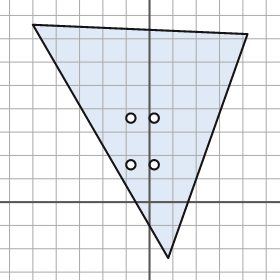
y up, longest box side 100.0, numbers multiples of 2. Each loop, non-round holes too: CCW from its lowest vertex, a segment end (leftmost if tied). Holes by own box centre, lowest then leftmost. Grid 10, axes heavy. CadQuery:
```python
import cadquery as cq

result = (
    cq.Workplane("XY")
    .moveTo(8.0, -24.0)
    .lineTo(42.0, 72.0)
    .lineTo(-50.0, 76.0)
    .close()
    .moveTo(-8.0, 16.0)
    .circle(2.0)
    .moveTo(2.0, 16.0)
    .circle(2.0)
    .moveTo(-8.0, 36.0)
    .circle(2.0)
    .moveTo(2.0, 36.0)
    .circle(2.0)
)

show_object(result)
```